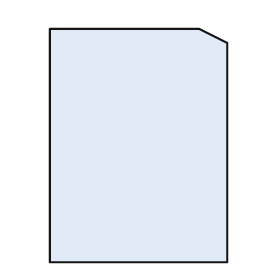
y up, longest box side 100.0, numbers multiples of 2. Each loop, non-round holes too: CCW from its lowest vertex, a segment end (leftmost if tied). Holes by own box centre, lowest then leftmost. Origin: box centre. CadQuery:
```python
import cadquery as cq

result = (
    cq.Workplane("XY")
    .moveTo(-38.0, -50.0)
    .lineTo(38.0, -50.0)
    .lineTo(38.0, 44.0)
    .lineTo(26.0, 50.0)
    .lineTo(-38.0, 50.0)
    .close()
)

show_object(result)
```